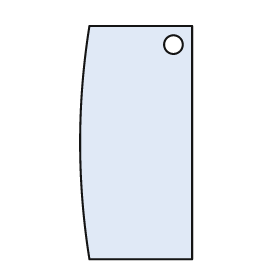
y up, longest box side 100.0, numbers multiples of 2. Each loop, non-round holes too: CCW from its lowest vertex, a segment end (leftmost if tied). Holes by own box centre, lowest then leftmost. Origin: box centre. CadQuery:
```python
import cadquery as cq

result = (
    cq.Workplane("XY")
    .moveTo(-20.0, -50.0)
    .lineTo(24.0, -50.0)
    .lineTo(24.0, 50.0)
    .lineTo(-20.0, 50.0)
    .threePointArc((-24.0, 0.0), (-20.0, -50.0))
    .close()
    .moveTo(16.0, 42.0)
    .circle(4.0)
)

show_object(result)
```